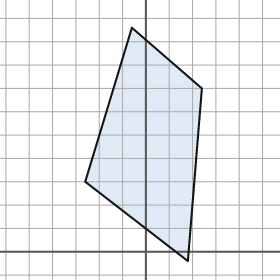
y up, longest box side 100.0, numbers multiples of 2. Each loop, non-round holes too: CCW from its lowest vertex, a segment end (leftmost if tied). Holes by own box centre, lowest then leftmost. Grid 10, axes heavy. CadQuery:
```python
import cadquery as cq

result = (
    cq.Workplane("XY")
    .moveTo(18.0, -4.0)
    .lineTo(24.0, 70.0)
    .lineTo(-6.0, 96.0)
    .lineTo(-26.0, 30.0)
    .close()
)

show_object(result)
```